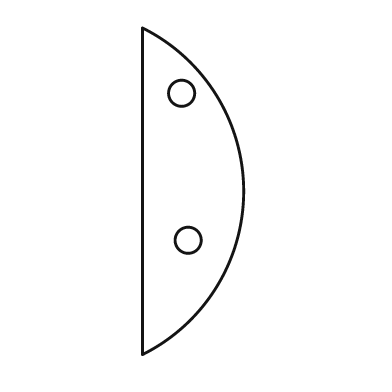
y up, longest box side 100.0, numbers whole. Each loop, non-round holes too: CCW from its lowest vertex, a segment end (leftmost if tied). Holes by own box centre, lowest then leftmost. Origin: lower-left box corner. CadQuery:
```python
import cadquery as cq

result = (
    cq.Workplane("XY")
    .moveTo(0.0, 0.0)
    .threePointArc((31.0, 50.0), (0.0, 100.0))
    .close()
    .moveTo(14.0, 35.0)
    .circle(4.0)
    .moveTo(12.0, 80.0)
    .circle(4.0)
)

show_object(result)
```